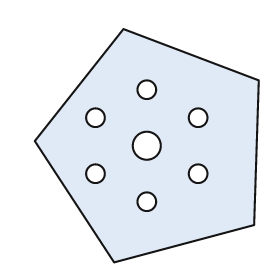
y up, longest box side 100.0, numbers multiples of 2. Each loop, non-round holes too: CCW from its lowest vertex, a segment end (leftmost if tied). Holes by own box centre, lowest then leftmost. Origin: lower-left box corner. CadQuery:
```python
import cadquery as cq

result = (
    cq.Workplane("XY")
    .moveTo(34.0, 0.0)
    .lineTo(94.0, 16.0)
    .lineTo(96.0, 78.0)
    .lineTo(38.0, 100.0)
    .lineTo(0.0, 52.0)
    .close()
    .moveTo(48.0, 26.0)
    .circle(4.0)
    .moveTo(26.0, 38.0)
    .circle(4.0)
    .moveTo(70.0, 38.0)
    .circle(4.0)
    .moveTo(48.0, 50.0)
    .circle(6.0)
    .moveTo(26.0, 62.0)
    .circle(4.0)
    .moveTo(70.0, 62.0)
    .circle(4.0)
    .moveTo(48.0, 74.0)
    .circle(4.0)
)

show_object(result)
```